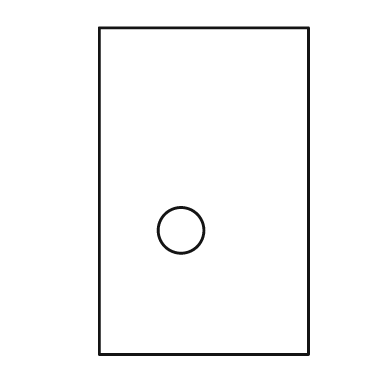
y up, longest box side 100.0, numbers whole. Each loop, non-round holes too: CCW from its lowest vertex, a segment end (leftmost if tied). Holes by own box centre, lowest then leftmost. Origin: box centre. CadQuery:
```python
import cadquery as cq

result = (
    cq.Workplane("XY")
    .moveTo(-32.0, -50.0)
    .lineTo(32.0, -50.0)
    .lineTo(32.0, 50.0)
    .lineTo(-32.0, 50.0)
    .close()
    .moveTo(-7.0, -12.0)
    .circle(7.0)
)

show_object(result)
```